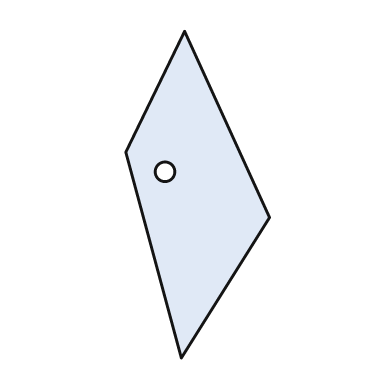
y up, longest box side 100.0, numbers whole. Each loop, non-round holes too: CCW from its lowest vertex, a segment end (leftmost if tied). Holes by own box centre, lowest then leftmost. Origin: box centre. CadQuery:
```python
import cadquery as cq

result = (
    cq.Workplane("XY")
    .moveTo(-5.0, -50.0)
    .lineTo(22.0, -7.0)
    .lineTo(-4.0, 50.0)
    .lineTo(-22.0, 13.0)
    .close()
    .moveTo(-10.0, 7.0)
    .circle(3.0)
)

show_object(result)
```